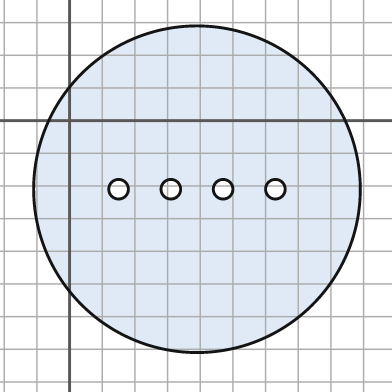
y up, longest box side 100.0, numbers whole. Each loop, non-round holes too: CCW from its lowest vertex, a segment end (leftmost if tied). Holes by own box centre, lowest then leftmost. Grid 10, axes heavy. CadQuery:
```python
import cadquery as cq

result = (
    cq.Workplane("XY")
    .moveTo(39.0, -21.0)
    .circle(50.0)
    .moveTo(15.0, -21.0)
    .circle(3.0)
    .moveTo(31.0, -21.0)
    .circle(3.0)
    .moveTo(47.0, -21.0)
    .circle(3.0)
    .moveTo(63.0, -21.0)
    .circle(3.0)
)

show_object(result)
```